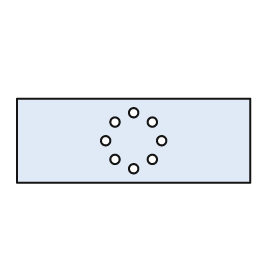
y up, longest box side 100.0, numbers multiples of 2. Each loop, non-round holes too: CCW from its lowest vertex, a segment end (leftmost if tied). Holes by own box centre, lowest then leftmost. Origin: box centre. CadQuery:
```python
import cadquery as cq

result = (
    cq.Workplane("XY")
    .moveTo(-50.0, -18.0)
    .lineTo(50.0, -18.0)
    .lineTo(50.0, 18.0)
    .lineTo(-50.0, 18.0)
    .close()
    .moveTo(0.0, -12.0)
    .circle(2.0)
    .moveTo(-8.0, -8.0)
    .circle(2.0)
    .moveTo(8.0, -8.0)
    .circle(2.0)
    .moveTo(-12.0, 0.0)
    .circle(2.0)
    .moveTo(12.0, 0.0)
    .circle(2.0)
    .moveTo(-8.0, 8.0)
    .circle(2.0)
    .moveTo(8.0, 8.0)
    .circle(2.0)
    .moveTo(0.0, 12.0)
    .circle(2.0)
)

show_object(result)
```